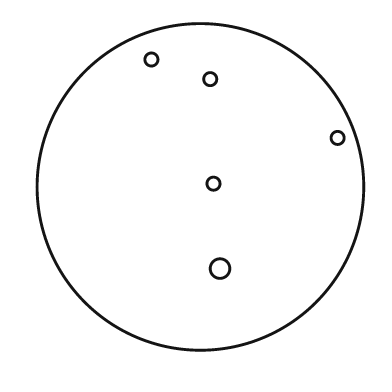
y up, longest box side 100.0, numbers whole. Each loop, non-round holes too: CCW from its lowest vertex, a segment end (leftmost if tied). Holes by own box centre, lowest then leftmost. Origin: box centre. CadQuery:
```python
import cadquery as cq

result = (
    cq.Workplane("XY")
    .moveTo(0.0, 0.0)
    .circle(50.0)
    .moveTo(6.0, -25.0)
    .circle(3.0)
    .moveTo(4.0, 1.0)
    .circle(2.0)
    .moveTo(42.0, 15.0)
    .circle(2.0)
    .moveTo(3.0, 33.0)
    .circle(2.0)
    .moveTo(-15.0, 39.0)
    .circle(2.0)
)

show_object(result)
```